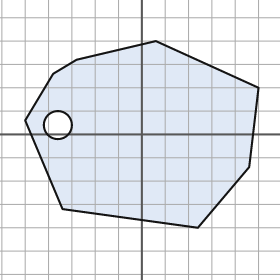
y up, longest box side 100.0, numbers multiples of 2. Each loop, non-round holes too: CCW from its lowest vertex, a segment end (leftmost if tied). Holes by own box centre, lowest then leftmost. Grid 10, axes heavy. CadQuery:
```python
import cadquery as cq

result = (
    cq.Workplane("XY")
    .moveTo(24.0, -40.0)
    .lineTo(46.0, -14.0)
    .lineTo(50.0, 20.0)
    .lineTo(6.0, 40.0)
    .lineTo(-28.0, 32.0)
    .lineTo(-38.0, 26.0)
    .lineTo(-50.0, 6.0)
    .lineTo(-34.0, -32.0)
    .close()
    .moveTo(-36.0, 4.0)
    .circle(6.0)
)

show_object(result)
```